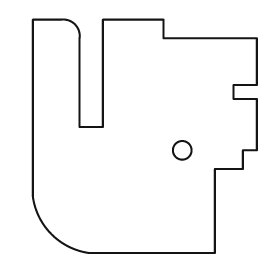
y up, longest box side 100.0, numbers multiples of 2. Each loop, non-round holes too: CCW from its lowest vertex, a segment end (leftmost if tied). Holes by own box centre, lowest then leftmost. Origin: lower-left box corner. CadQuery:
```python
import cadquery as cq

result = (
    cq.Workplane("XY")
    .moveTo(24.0, 0.0)
    .lineTo(78.0, 0.0)
    .lineTo(78.0, 36.0)
    .lineTo(90.0, 36.0)
    .lineTo(90.0, 44.0)
    .lineTo(96.0, 44.0)
    .lineTo(96.0, 66.0)
    .lineTo(86.0, 66.0)
    .lineTo(86.0, 72.0)
    .lineTo(96.0, 72.0)
    .lineTo(96.0, 92.0)
    .lineTo(56.0, 92.0)
    .lineTo(56.0, 100.0)
    .lineTo(30.0, 100.0)
    .lineTo(30.0, 54.0)
    .lineTo(20.0, 54.0)
    .lineTo(20.0, 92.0)
    .threePointArc((18.0, 98.0), (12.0, 100.0))
    .lineTo(0.0, 100.0)
    .lineTo(0.0, 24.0)
    .threePointArc((8.0, 8.0), (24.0, 0.0))
    .close()
    .moveTo(64.0, 44.0)
    .circle(4.0)
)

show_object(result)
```